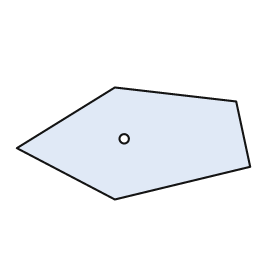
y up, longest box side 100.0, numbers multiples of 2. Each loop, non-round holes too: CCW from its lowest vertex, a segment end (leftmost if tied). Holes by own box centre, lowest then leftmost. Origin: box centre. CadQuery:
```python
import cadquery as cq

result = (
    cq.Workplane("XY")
    .moveTo(-8.0, -24.0)
    .lineTo(50.0, -10.0)
    .lineTo(44.0, 18.0)
    .lineTo(-8.0, 24.0)
    .lineTo(-50.0, -2.0)
    .close()
    .moveTo(-4.0, 2.0)
    .circle(2.0)
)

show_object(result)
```